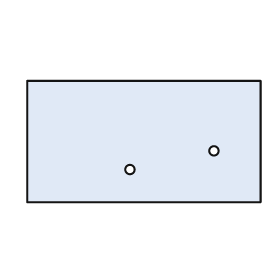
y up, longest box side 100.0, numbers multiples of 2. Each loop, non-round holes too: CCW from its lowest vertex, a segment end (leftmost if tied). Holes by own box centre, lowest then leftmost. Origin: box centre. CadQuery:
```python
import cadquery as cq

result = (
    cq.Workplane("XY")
    .moveTo(-50.0, -26.0)
    .lineTo(50.0, -26.0)
    .lineTo(50.0, 26.0)
    .lineTo(-50.0, 26.0)
    .close()
    .moveTo(-6.0, -12.0)
    .circle(2.0)
    .moveTo(30.0, -4.0)
    .circle(2.0)
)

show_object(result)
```